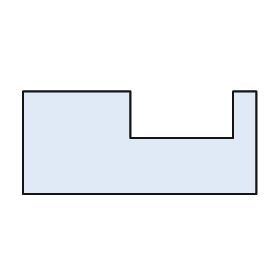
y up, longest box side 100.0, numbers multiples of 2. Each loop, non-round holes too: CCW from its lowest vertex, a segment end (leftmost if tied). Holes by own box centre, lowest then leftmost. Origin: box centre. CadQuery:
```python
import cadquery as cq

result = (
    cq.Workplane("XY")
    .moveTo(-50.0, -22.0)
    .lineTo(50.0, -22.0)
    .lineTo(50.0, 22.0)
    .lineTo(40.0, 22.0)
    .lineTo(40.0, 2.0)
    .lineTo(-4.0, 2.0)
    .lineTo(-4.0, 22.0)
    .lineTo(-50.0, 22.0)
    .close()
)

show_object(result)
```